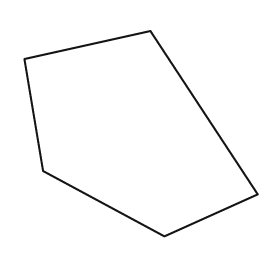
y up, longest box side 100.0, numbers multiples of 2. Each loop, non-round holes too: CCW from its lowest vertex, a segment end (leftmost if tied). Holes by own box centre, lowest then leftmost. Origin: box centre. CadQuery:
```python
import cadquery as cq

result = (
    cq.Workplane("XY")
    .moveTo(10.0, -44.0)
    .lineTo(50.0, -26.0)
    .lineTo(4.0, 44.0)
    .lineTo(-50.0, 32.0)
    .lineTo(-42.0, -16.0)
    .close()
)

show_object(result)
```